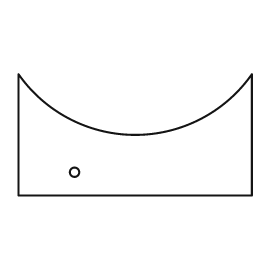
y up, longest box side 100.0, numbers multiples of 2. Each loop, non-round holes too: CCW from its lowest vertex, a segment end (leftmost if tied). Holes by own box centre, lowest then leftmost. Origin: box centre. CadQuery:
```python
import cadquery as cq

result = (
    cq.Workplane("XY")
    .moveTo(-50.0, -26.0)
    .lineTo(50.0, -26.0)
    .lineTo(50.0, 26.0)
    .threePointArc((0.0, 0.0), (-50.0, 26.0))
    .close()
    .moveTo(-26.0, -16.0)
    .circle(2.0)
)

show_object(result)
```